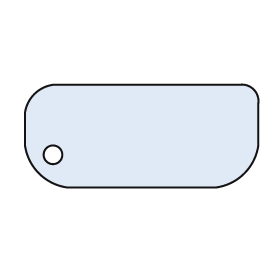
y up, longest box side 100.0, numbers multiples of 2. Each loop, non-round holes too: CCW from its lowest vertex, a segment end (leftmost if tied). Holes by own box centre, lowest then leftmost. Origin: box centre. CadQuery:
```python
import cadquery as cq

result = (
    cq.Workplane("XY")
    .moveTo(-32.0, -22.0)
    .lineTo(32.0, -22.0)
    .threePointArc((44.0, -16.0), (50.0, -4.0))
    .lineTo(50.0, 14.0)
    .threePointArc((48.0, 20.0), (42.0, 22.0))
    .lineTo(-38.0, 22.0)
    .threePointArc((-46.0, 18.0), (-50.0, 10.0))
    .lineTo(-50.0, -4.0)
    .threePointArc((-44.0, -16.0), (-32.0, -22.0))
    .close()
    .moveTo(-38.0, -8.0)
    .circle(4.0)
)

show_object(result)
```